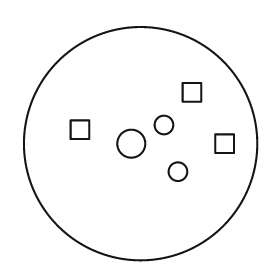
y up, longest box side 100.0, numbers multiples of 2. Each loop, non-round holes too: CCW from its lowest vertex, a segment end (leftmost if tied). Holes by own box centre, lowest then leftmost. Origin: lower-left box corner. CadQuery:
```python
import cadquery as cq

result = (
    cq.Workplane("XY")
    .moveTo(50.0, 50.0)
    .circle(50.0)
    .moveTo(66.0, 38.0)
    .circle(4.0)
    .moveTo(46.0, 50.0)
    .circle(6.0)
    .moveTo(82.0, 46.0)
    .lineTo(90.0, 46.0)
    .lineTo(90.0, 54.0)
    .lineTo(82.0, 54.0)
    .close()
    .moveTo(20.0, 52.0)
    .lineTo(28.0, 52.0)
    .lineTo(28.0, 60.0)
    .lineTo(20.0, 60.0)
    .close()
    .moveTo(60.0, 58.0)
    .circle(4.0)
    .moveTo(68.0, 68.0)
    .lineTo(76.0, 68.0)
    .lineTo(76.0, 76.0)
    .lineTo(68.0, 76.0)
    .close()
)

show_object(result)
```